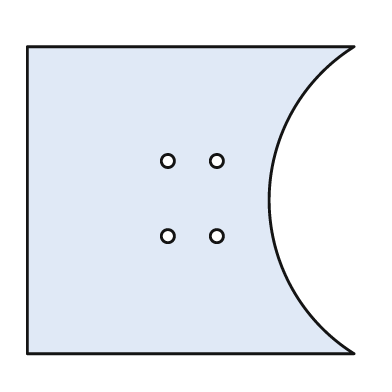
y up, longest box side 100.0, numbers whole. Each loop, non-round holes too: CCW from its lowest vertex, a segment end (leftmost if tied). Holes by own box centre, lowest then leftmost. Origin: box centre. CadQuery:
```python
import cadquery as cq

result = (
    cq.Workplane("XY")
    .moveTo(-50.0, -47.0)
    .lineTo(50.0, -47.0)
    .threePointArc((24.0, 0.0), (50.0, 47.0))
    .lineTo(-50.0, 47.0)
    .close()
    .moveTo(-7.0, -11.0)
    .circle(2.0)
    .moveTo(8.0, -11.0)
    .circle(2.0)
    .moveTo(-7.0, 12.0)
    .circle(2.0)
    .moveTo(8.0, 12.0)
    .circle(2.0)
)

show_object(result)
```